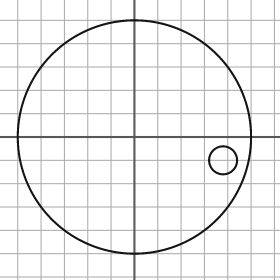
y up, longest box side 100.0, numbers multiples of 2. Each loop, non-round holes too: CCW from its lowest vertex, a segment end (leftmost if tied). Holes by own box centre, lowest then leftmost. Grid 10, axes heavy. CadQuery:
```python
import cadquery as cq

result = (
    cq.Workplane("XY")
    .moveTo(0.0, 0.0)
    .circle(50.0)
    .moveTo(38.0, -10.0)
    .circle(6.0)
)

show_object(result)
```